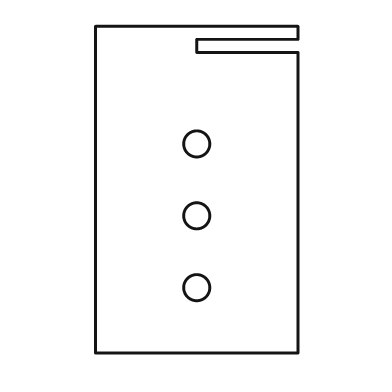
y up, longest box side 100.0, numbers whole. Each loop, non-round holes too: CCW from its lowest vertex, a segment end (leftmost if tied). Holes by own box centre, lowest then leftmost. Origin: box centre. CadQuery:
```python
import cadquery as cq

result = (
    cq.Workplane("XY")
    .moveTo(-31.0, -50.0)
    .lineTo(31.0, -50.0)
    .lineTo(31.0, 42.0)
    .lineTo(0.0, 42.0)
    .lineTo(0.0, 46.0)
    .lineTo(31.0, 46.0)
    .lineTo(31.0, 50.0)
    .lineTo(-31.0, 50.0)
    .close()
    .moveTo(0.0, -30.0)
    .circle(4.0)
    .moveTo(0.0, -8.0)
    .circle(4.0)
    .moveTo(0.0, 14.0)
    .circle(4.0)
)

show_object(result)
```